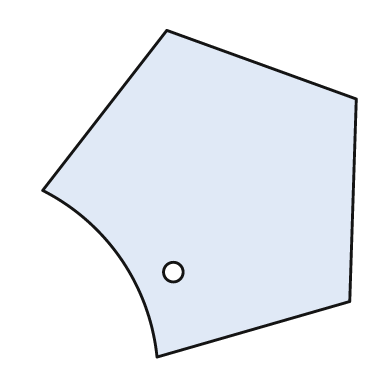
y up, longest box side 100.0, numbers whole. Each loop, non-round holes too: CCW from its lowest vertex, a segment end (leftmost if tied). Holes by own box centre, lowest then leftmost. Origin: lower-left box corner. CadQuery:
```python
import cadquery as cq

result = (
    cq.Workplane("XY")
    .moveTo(35.0, 0.0)
    .lineTo(94.0, 17.0)
    .lineTo(96.0, 79.0)
    .lineTo(38.0, 100.0)
    .lineTo(0.0, 51.0)
    .threePointArc((24.0, 30.0), (35.0, 0.0))
    .close()
    .moveTo(40.0, 26.0)
    .circle(3.0)
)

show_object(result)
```